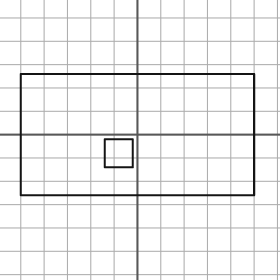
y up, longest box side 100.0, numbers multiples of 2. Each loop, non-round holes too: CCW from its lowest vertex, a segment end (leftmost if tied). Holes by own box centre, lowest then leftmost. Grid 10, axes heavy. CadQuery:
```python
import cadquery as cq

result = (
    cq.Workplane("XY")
    .moveTo(-50.0, -26.0)
    .lineTo(50.0, -26.0)
    .lineTo(50.0, 26.0)
    .lineTo(-50.0, 26.0)
    .close()
    .moveTo(-14.0, -14.0)
    .lineTo(-2.0, -14.0)
    .lineTo(-2.0, -2.0)
    .lineTo(-14.0, -2.0)
    .close()
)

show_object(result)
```